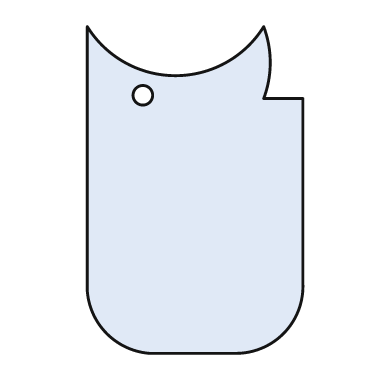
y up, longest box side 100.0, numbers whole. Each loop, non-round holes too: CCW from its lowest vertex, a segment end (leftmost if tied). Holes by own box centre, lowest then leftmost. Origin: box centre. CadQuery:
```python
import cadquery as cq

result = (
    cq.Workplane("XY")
    .moveTo(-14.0, -50.0)
    .lineTo(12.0, -50.0)
    .threePointArc((27.0, -44.0), (33.0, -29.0))
    .lineTo(33.0, 28.0)
    .lineTo(21.0, 28.0)
    .threePointArc((23.0, 39.0), (21.0, 50.0))
    .threePointArc((-6.0, 35.0), (-33.0, 50.0))
    .lineTo(-33.0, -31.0)
    .threePointArc((-27.0, -44.0), (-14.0, -50.0))
    .close()
    .moveTo(-16.0, 29.0)
    .circle(3.0)
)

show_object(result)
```